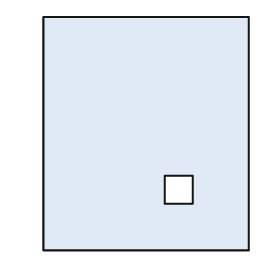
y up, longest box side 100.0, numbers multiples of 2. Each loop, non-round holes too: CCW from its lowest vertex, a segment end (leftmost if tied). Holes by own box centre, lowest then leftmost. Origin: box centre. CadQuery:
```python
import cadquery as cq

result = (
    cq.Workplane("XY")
    .moveTo(-44.0, -50.0)
    .lineTo(44.0, -50.0)
    .lineTo(44.0, 50.0)
    .lineTo(-44.0, 50.0)
    .close()
    .moveTo(8.0, -30.0)
    .lineTo(20.0, -30.0)
    .lineTo(20.0, -18.0)
    .lineTo(8.0, -18.0)
    .close()
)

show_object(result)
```